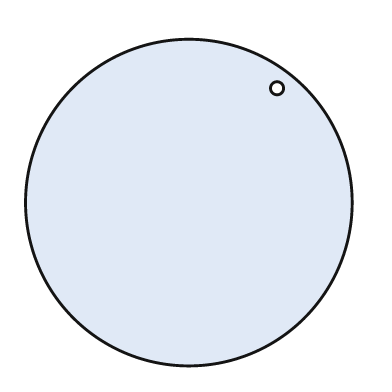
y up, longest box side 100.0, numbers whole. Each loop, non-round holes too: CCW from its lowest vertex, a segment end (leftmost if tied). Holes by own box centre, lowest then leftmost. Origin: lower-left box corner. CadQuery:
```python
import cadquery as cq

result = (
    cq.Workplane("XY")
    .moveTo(50.0, 50.0)
    .circle(50.0)
    .moveTo(77.0, 85.0)
    .circle(2.0)
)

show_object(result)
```